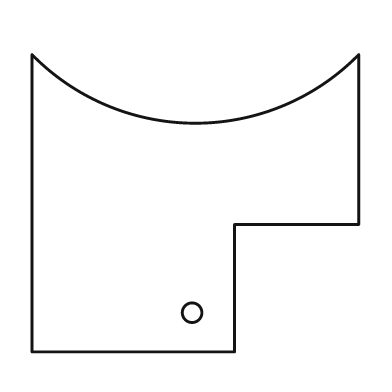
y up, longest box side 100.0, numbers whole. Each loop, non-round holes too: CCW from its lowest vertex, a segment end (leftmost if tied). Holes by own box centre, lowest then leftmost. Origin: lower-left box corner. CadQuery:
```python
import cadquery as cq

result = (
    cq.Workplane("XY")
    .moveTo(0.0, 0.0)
    .lineTo(62.0, 0.0)
    .lineTo(62.0, 39.0)
    .lineTo(100.0, 39.0)
    .lineTo(100.0, 91.0)
    .threePointArc((50.0, 70.0), (0.0, 91.0))
    .close()
    .moveTo(49.0, 12.0)
    .circle(3.0)
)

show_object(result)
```